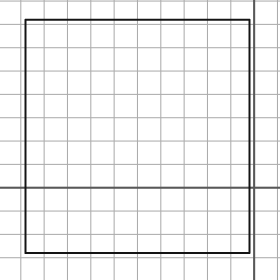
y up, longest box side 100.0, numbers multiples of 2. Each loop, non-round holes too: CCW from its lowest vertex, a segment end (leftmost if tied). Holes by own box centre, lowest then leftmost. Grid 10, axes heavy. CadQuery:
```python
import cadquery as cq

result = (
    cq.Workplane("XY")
    .moveTo(-98.0, -28.0)
    .lineTo(-2.0, -28.0)
    .lineTo(-2.0, 72.0)
    .lineTo(-98.0, 72.0)
    .close()
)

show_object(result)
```